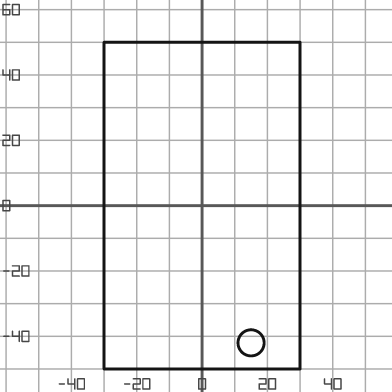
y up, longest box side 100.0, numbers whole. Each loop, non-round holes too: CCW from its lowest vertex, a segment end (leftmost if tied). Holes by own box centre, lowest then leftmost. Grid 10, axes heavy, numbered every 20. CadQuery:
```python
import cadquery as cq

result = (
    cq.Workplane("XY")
    .moveTo(-30.0, -50.0)
    .lineTo(30.0, -50.0)
    .lineTo(30.0, 50.0)
    .lineTo(-30.0, 50.0)
    .close()
    .moveTo(15.0, -42.0)
    .circle(4.0)
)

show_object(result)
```